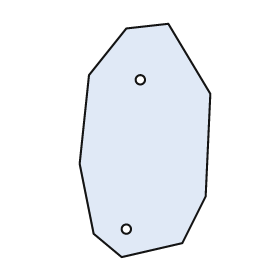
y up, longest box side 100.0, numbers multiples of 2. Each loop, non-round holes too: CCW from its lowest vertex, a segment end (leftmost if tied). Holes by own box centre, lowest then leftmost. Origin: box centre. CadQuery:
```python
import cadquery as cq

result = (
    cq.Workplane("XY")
    .moveTo(-10.0, -50.0)
    .lineTo(16.0, -44.0)
    .lineTo(26.0, -24.0)
    .lineTo(28.0, 20.0)
    .lineTo(10.0, 50.0)
    .lineTo(-8.0, 48.0)
    .lineTo(-24.0, 28.0)
    .lineTo(-28.0, -10.0)
    .lineTo(-22.0, -40.0)
    .close()
    .moveTo(-8.0, -38.0)
    .circle(2.0)
    .moveTo(-2.0, 26.0)
    .circle(2.0)
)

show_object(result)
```